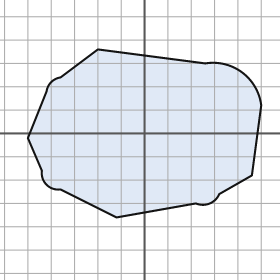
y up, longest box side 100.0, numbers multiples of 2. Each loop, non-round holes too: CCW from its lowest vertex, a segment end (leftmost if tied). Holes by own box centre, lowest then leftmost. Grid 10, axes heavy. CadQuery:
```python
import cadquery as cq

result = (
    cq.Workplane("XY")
    .moveTo(-12.0, -36.0)
    .lineTo(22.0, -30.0)
    .threePointArc((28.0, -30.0), (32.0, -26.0))
    .lineTo(46.0, -18.0)
    .lineTo(50.0, 12.0)
    .threePointArc((42.0, 26.0), (26.0, 30.0))
    .lineTo(-20.0, 36.0)
    .lineTo(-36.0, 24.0)
    .threePointArc((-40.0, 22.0), (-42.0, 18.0))
    .lineTo(-50.0, -2.0)
    .lineTo(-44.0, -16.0)
    .threePointArc((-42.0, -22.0), (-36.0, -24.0))
    .close()
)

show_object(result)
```